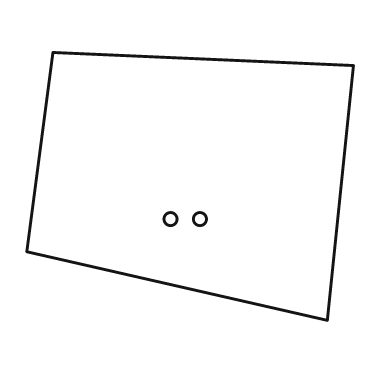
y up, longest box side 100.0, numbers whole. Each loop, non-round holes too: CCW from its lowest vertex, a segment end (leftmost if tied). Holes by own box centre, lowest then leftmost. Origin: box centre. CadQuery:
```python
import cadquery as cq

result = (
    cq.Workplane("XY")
    .moveTo(42.0, -41.0)
    .lineTo(50.0, 37.0)
    .lineTo(-42.0, 41.0)
    .lineTo(-50.0, -20.0)
    .close()
    .moveTo(-6.0, -10.0)
    .circle(2.0)
    .moveTo(3.0, -10.0)
    .circle(2.0)
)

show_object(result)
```